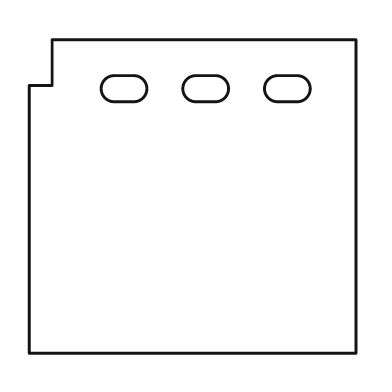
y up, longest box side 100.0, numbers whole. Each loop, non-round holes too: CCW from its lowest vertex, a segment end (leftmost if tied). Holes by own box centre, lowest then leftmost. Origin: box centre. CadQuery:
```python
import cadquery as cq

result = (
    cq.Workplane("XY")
    .moveTo(-50.0, -48.0)
    .lineTo(50.0, -48.0)
    .lineTo(50.0, 48.0)
    .lineTo(-43.0, 48.0)
    .lineTo(-43.0, 34.0)
    .lineTo(-50.0, 34.0)
    .close()
    .moveTo(-24.0, 29.0)
    .lineTo(-18.0, 29.0)
    .threePointArc((-14.0, 33.0), (-18.0, 37.0))
    .lineTo(-24.0, 37.0)
    .threePointArc((-28.0, 33.0), (-24.0, 29.0))
    .close()
    .moveTo(1.0, 29.0)
    .lineTo(7.0, 29.0)
    .threePointArc((11.0, 33.0), (7.0, 37.0))
    .lineTo(1.0, 37.0)
    .threePointArc((-3.0, 33.0), (1.0, 29.0))
    .close()
    .moveTo(26.0, 29.0)
    .lineTo(32.0, 29.0)
    .threePointArc((36.0, 33.0), (32.0, 37.0))
    .lineTo(26.0, 37.0)
    .threePointArc((22.0, 33.0), (26.0, 29.0))
    .close()
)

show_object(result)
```